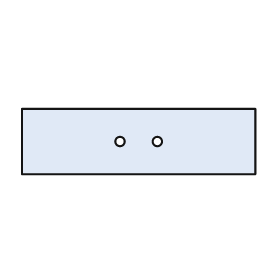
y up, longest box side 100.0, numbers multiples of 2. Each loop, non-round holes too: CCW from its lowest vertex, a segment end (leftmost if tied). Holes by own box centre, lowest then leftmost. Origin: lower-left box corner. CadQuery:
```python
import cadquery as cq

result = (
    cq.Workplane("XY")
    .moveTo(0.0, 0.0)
    .lineTo(100.0, 0.0)
    .lineTo(100.0, 28.0)
    .lineTo(0.0, 28.0)
    .close()
    .moveTo(42.0, 14.0)
    .circle(2.0)
    .moveTo(58.0, 14.0)
    .circle(2.0)
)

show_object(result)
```